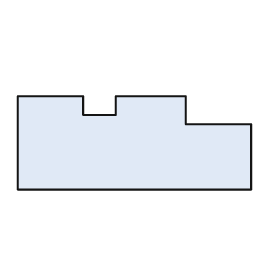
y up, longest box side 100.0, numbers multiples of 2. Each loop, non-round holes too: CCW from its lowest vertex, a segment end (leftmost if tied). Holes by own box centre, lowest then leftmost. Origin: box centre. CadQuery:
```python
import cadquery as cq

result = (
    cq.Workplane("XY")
    .moveTo(-50.0, -20.0)
    .lineTo(50.0, -20.0)
    .lineTo(50.0, 8.0)
    .lineTo(22.0, 8.0)
    .lineTo(22.0, 20.0)
    .lineTo(-8.0, 20.0)
    .lineTo(-8.0, 12.0)
    .lineTo(-22.0, 12.0)
    .lineTo(-22.0, 20.0)
    .lineTo(-50.0, 20.0)
    .close()
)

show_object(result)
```